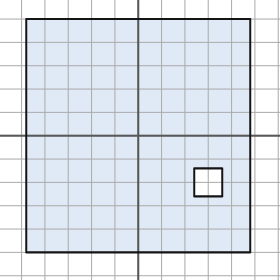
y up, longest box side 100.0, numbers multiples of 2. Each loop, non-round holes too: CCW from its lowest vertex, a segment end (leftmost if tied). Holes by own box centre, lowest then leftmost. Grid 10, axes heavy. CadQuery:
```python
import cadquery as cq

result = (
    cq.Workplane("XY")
    .moveTo(-48.0, -50.0)
    .lineTo(48.0, -50.0)
    .lineTo(48.0, 50.0)
    .lineTo(-48.0, 50.0)
    .close()
    .moveTo(24.0, -26.0)
    .lineTo(36.0, -26.0)
    .lineTo(36.0, -14.0)
    .lineTo(24.0, -14.0)
    .close()
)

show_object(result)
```